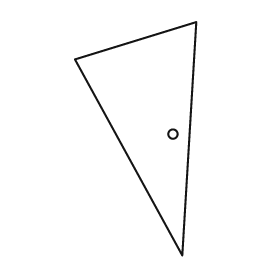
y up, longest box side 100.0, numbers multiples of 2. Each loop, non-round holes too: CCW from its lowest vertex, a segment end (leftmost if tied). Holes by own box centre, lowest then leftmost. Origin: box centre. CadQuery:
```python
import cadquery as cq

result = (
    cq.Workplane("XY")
    .moveTo(20.0, -50.0)
    .lineTo(26.0, 50.0)
    .lineTo(-26.0, 34.0)
    .close()
    .moveTo(16.0, 2.0)
    .circle(2.0)
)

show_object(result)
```